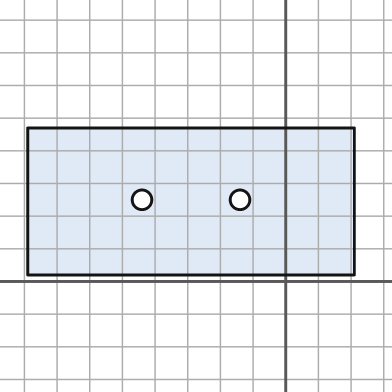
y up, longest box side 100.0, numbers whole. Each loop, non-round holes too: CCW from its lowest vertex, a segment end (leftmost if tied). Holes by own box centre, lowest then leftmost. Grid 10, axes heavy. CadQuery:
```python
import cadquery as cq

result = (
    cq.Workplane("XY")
    .moveTo(-79.0, 2.0)
    .lineTo(21.0, 2.0)
    .lineTo(21.0, 47.0)
    .lineTo(-79.0, 47.0)
    .close()
    .moveTo(-44.0, 25.0)
    .circle(3.0)
    .moveTo(-14.0, 25.0)
    .circle(3.0)
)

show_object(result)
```